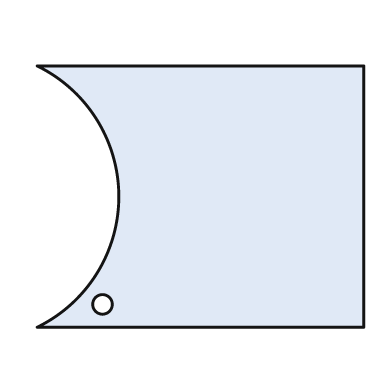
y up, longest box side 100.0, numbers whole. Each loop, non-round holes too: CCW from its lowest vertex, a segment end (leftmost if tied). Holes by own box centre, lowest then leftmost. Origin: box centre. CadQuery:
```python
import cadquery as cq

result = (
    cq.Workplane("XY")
    .moveTo(-50.0, -40.0)
    .lineTo(50.0, -40.0)
    .lineTo(50.0, 40.0)
    .lineTo(-50.0, 40.0)
    .threePointArc((-25.0, 0.0), (-50.0, -40.0))
    .close()
    .moveTo(-30.0, -33.0)
    .circle(3.0)
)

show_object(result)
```